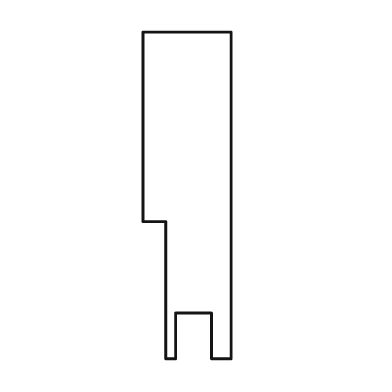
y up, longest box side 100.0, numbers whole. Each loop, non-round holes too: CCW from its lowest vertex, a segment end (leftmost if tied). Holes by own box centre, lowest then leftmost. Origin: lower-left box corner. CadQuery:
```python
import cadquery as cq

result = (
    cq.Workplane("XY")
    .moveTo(7.0, 0.0)
    .lineTo(10.0, 0.0)
    .lineTo(10.0, 14.0)
    .lineTo(21.0, 14.0)
    .lineTo(21.0, 0.0)
    .lineTo(27.0, 0.0)
    .lineTo(27.0, 100.0)
    .lineTo(0.0, 100.0)
    .lineTo(0.0, 42.0)
    .lineTo(7.0, 42.0)
    .close()
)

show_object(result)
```